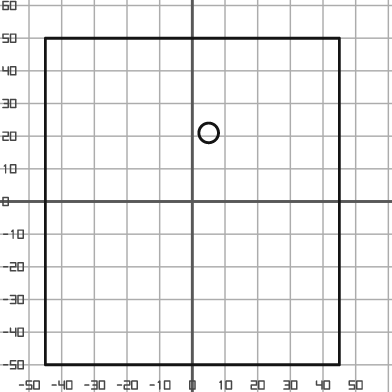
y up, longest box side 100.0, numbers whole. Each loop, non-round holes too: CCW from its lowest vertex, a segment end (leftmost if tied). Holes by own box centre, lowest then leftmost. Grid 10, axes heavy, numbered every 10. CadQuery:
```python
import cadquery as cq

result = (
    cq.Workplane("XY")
    .moveTo(-45.0, -50.0)
    .lineTo(45.0, -50.0)
    .lineTo(45.0, 50.0)
    .lineTo(-45.0, 50.0)
    .close()
    .moveTo(5.0, 21.0)
    .circle(3.0)
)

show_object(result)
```